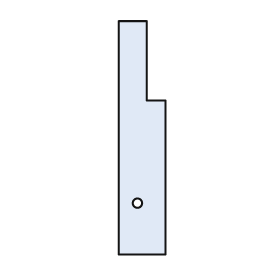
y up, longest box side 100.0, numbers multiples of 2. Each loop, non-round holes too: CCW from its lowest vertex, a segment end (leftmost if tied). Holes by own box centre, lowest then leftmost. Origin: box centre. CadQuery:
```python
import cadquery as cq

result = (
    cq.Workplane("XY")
    .moveTo(-10.0, -50.0)
    .lineTo(10.0, -50.0)
    .lineTo(10.0, 16.0)
    .lineTo(2.0, 16.0)
    .lineTo(2.0, 50.0)
    .lineTo(-10.0, 50.0)
    .close()
    .moveTo(-2.0, -28.0)
    .circle(2.0)
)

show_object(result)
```